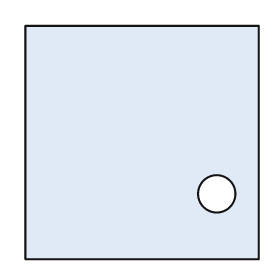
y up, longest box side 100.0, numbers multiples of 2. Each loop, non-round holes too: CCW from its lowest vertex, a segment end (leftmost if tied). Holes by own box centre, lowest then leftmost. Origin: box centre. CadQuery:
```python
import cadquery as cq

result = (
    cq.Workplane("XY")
    .moveTo(-50.0, -50.0)
    .lineTo(50.0, -50.0)
    .lineTo(50.0, 50.0)
    .lineTo(-50.0, 50.0)
    .close()
    .moveTo(32.0, -22.0)
    .circle(8.0)
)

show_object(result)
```